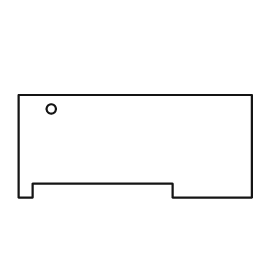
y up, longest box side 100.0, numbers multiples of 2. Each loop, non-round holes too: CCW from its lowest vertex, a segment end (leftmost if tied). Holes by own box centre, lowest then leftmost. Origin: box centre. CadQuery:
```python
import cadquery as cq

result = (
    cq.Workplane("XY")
    .moveTo(-50.0, -22.0)
    .lineTo(-44.0, -22.0)
    .lineTo(-44.0, -16.0)
    .lineTo(16.0, -16.0)
    .lineTo(16.0, -22.0)
    .lineTo(50.0, -22.0)
    .lineTo(50.0, 22.0)
    .lineTo(-50.0, 22.0)
    .close()
    .moveTo(-36.0, 16.0)
    .circle(2.0)
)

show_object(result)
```